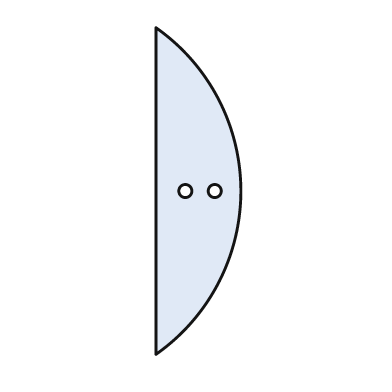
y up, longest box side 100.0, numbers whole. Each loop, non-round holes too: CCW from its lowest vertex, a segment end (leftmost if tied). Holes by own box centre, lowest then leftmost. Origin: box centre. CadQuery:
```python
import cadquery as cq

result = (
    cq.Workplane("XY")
    .moveTo(-13.0, -50.0)
    .threePointArc((13.0, 0.0), (-13.0, 50.0))
    .close()
    .moveTo(-4.0, 0.0)
    .circle(2.0)
    .moveTo(5.0, 0.0)
    .circle(2.0)
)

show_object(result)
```